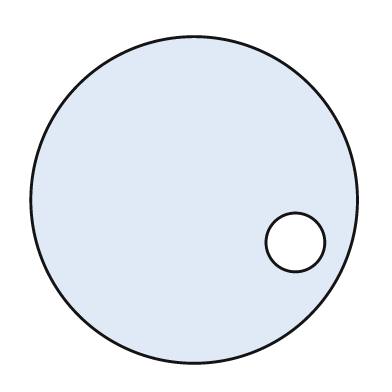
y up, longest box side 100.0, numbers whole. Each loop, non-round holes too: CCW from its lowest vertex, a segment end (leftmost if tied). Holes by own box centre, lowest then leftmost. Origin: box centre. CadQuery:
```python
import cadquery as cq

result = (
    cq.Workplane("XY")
    .moveTo(0.0, 0.0)
    .circle(50.0)
    .moveTo(31.0, -13.0)
    .circle(9.0)
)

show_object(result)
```